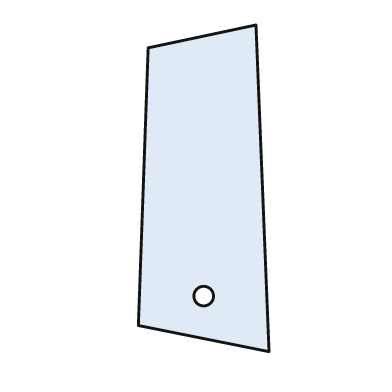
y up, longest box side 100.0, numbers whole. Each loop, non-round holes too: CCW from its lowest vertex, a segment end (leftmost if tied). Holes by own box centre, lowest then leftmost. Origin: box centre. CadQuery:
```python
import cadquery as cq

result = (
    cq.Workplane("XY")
    .moveTo(20.0, -50.0)
    .lineTo(16.0, 50.0)
    .lineTo(-17.0, 43.0)
    .lineTo(-20.0, -42.0)
    .close()
    .moveTo(0.0, -33.0)
    .circle(3.0)
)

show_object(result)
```